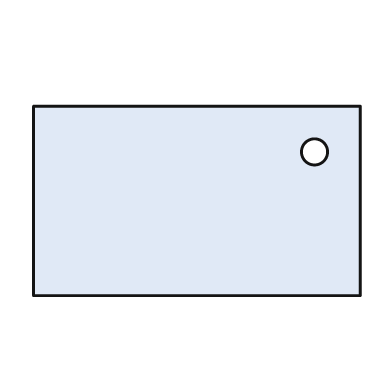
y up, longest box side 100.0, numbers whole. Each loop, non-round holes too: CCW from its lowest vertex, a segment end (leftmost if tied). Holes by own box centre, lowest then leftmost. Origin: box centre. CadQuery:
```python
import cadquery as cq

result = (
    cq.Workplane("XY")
    .moveTo(-50.0, -29.0)
    .lineTo(50.0, -29.0)
    .lineTo(50.0, 29.0)
    .lineTo(-50.0, 29.0)
    .close()
    .moveTo(36.0, 15.0)
    .circle(4.0)
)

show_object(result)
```